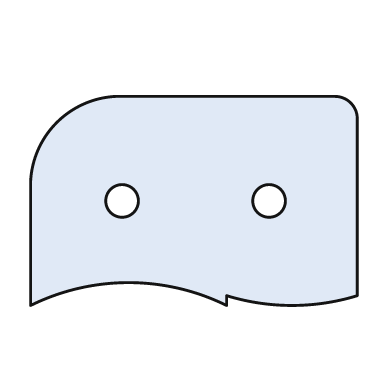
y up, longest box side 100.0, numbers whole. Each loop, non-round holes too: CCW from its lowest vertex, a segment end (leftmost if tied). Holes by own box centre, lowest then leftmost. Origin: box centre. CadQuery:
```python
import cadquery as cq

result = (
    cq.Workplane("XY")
    .moveTo(-50.0, -32.0)
    .threePointArc((-20.0, -25.0), (10.0, -32.0))
    .lineTo(10.0, -29.0)
    .threePointArc((30.0, -32.0), (50.0, -29.0))
    .lineTo(50.0, 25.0)
    .threePointArc((48.0, 30.0), (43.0, 32.0))
    .lineTo(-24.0, 32.0)
    .threePointArc((-42.0, 24.0), (-50.0, 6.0))
    .close()
    .moveTo(-22.0, 0.0)
    .circle(5.0)
    .moveTo(23.0, 0.0)
    .circle(5.0)
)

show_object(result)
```